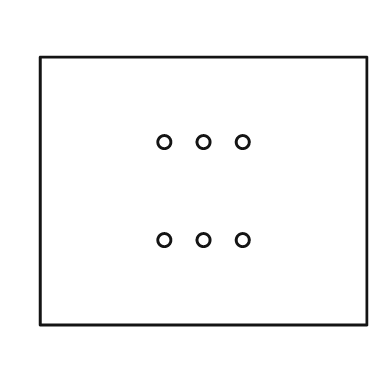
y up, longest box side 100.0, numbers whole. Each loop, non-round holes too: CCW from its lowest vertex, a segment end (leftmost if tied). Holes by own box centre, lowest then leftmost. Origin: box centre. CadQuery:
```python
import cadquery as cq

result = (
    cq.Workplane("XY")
    .moveTo(-50.0, -41.0)
    .lineTo(50.0, -41.0)
    .lineTo(50.0, 41.0)
    .lineTo(-50.0, 41.0)
    .close()
    .moveTo(-12.0, -15.0)
    .circle(2.0)
    .moveTo(0.0, -15.0)
    .circle(2.0)
    .moveTo(12.0, -15.0)
    .circle(2.0)
    .moveTo(-12.0, 15.0)
    .circle(2.0)
    .moveTo(0.0, 15.0)
    .circle(2.0)
    .moveTo(12.0, 15.0)
    .circle(2.0)
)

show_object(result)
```